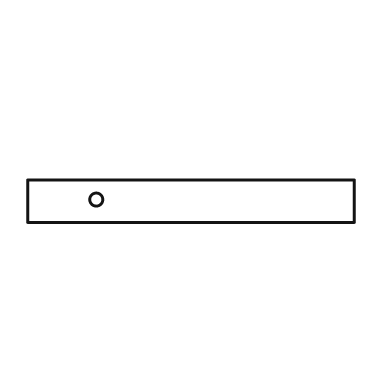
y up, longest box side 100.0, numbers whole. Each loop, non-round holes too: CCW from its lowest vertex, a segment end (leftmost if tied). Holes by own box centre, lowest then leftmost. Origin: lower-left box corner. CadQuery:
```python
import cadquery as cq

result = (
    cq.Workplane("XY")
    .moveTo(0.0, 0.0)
    .lineTo(100.0, 0.0)
    .lineTo(100.0, 13.0)
    .lineTo(0.0, 13.0)
    .close()
    .moveTo(21.0, 7.0)
    .circle(2.0)
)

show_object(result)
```